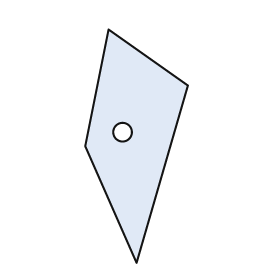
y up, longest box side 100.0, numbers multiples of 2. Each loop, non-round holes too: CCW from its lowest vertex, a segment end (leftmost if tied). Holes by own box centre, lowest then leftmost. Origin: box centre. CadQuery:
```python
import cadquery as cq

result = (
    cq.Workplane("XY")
    .moveTo(0.0, -50.0)
    .lineTo(22.0, 26.0)
    .lineTo(-12.0, 50.0)
    .lineTo(-22.0, 0.0)
    .close()
    .moveTo(-6.0, 6.0)
    .circle(4.0)
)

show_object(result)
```